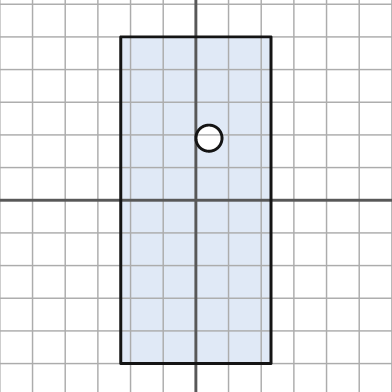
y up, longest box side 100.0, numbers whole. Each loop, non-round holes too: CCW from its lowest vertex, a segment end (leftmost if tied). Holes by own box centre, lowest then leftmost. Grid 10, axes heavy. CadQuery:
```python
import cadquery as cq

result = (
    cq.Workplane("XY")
    .moveTo(-23.0, -50.0)
    .lineTo(23.0, -50.0)
    .lineTo(23.0, 50.0)
    .lineTo(-23.0, 50.0)
    .close()
    .moveTo(4.0, 19.0)
    .circle(4.0)
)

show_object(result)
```